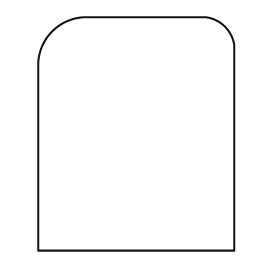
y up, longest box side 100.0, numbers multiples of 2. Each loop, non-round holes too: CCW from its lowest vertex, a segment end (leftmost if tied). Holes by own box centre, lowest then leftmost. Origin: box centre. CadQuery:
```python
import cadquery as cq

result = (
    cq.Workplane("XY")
    .moveTo(-42.0, -50.0)
    .lineTo(42.0, -50.0)
    .lineTo(42.0, 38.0)
    .threePointArc((38.0, 46.0), (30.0, 50.0))
    .lineTo(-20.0, 50.0)
    .threePointArc((-36.0, 44.0), (-42.0, 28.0))
    .close()
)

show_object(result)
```